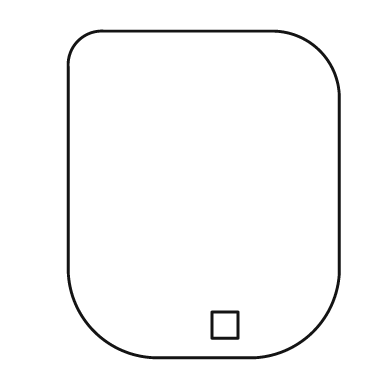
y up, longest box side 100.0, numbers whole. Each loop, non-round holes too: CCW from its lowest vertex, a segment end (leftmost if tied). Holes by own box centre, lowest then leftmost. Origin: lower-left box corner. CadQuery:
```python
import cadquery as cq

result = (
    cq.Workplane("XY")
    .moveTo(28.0, 0.0)
    .lineTo(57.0, 0.0)
    .threePointArc((75.0, 8.0), (83.0, 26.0))
    .lineTo(83.0, 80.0)
    .threePointArc((77.0, 94.0), (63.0, 100.0))
    .lineTo(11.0, 100.0)
    .threePointArc((3.0, 97.0), (0.0, 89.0))
    .lineTo(0.0, 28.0)
    .threePointArc((8.0, 8.0), (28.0, 0.0))
    .close()
    .moveTo(44.0, 6.0)
    .lineTo(52.0, 6.0)
    .lineTo(52.0, 14.0)
    .lineTo(44.0, 14.0)
    .close()
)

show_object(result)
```